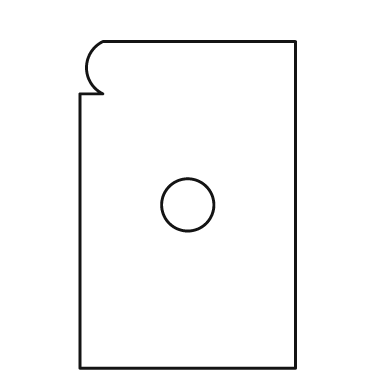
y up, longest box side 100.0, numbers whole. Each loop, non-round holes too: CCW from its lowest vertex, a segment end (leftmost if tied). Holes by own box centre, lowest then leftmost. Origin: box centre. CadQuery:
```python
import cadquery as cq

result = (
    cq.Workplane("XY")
    .moveTo(-33.0, -50.0)
    .lineTo(33.0, -50.0)
    .lineTo(33.0, 50.0)
    .lineTo(-26.0, 50.0)
    .threePointArc((-31.0, 42.0), (-26.0, 34.0))
    .lineTo(-33.0, 34.0)
    .close()
    .moveTo(0.0, 0.0)
    .circle(8.0)
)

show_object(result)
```